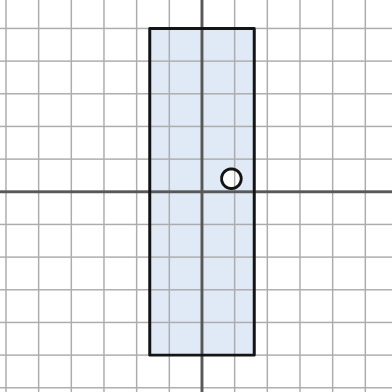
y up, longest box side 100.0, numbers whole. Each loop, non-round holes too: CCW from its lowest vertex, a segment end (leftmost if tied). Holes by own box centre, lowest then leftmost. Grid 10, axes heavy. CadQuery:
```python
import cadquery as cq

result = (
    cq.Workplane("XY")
    .moveTo(-16.0, -50.0)
    .lineTo(16.0, -50.0)
    .lineTo(16.0, 50.0)
    .lineTo(-16.0, 50.0)
    .close()
    .moveTo(9.0, 4.0)
    .circle(3.0)
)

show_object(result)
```